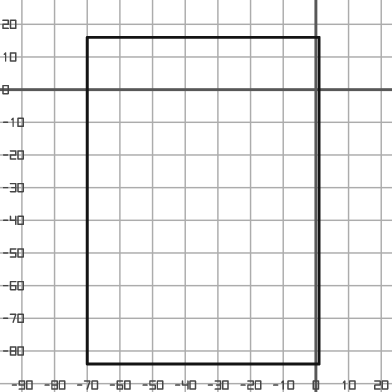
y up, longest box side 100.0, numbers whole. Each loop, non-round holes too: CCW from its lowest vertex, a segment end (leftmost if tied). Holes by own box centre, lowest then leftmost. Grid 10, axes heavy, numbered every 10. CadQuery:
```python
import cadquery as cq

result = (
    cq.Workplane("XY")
    .moveTo(-70.0, -84.0)
    .lineTo(1.0, -84.0)
    .lineTo(1.0, 16.0)
    .lineTo(-70.0, 16.0)
    .close()
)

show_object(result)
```